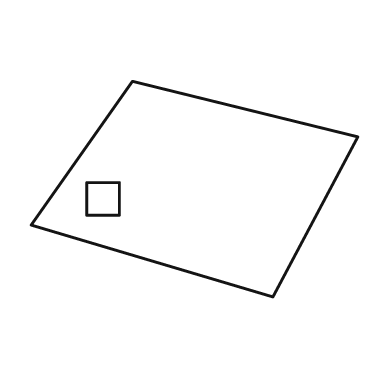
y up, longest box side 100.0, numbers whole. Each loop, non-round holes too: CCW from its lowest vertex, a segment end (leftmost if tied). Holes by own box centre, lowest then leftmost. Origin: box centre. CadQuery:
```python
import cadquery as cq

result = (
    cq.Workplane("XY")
    .moveTo(24.0, -33.0)
    .lineTo(50.0, 16.0)
    .lineTo(-19.0, 33.0)
    .lineTo(-50.0, -11.0)
    .close()
    .moveTo(-33.0, -8.0)
    .lineTo(-23.0, -8.0)
    .lineTo(-23.0, 2.0)
    .lineTo(-33.0, 2.0)
    .close()
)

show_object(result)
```